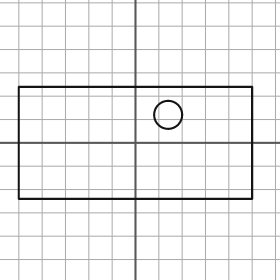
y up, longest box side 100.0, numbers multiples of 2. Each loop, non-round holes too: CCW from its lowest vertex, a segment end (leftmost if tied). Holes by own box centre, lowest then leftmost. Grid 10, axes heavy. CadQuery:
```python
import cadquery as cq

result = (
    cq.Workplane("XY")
    .moveTo(-50.0, -24.0)
    .lineTo(50.0, -24.0)
    .lineTo(50.0, 24.0)
    .lineTo(-50.0, 24.0)
    .close()
    .moveTo(14.0, 12.0)
    .circle(6.0)
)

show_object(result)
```